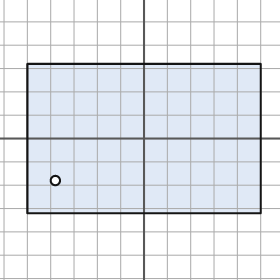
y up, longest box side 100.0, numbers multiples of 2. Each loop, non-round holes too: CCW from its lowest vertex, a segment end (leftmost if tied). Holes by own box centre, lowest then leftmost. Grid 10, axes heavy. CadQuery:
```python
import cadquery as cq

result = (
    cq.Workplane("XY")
    .moveTo(-50.0, -32.0)
    .lineTo(50.0, -32.0)
    .lineTo(50.0, 32.0)
    .lineTo(-50.0, 32.0)
    .close()
    .moveTo(-38.0, -18.0)
    .circle(2.0)
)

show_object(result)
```